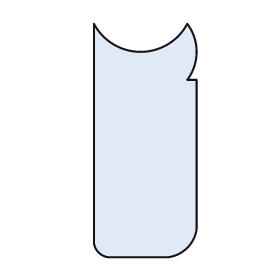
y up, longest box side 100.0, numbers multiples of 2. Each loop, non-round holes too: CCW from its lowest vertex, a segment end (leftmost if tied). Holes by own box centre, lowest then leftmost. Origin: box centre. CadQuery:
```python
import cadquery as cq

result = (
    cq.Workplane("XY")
    .moveTo(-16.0, -50.0)
    .lineTo(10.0, -50.0)
    .threePointArc((18.0, -46.0), (22.0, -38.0))
    .lineTo(22.0, 26.0)
    .lineTo(18.0, 26.0)
    .threePointArc((22.0, 38.0), (18.0, 50.0))
    .threePointArc((-2.0, 38.0), (-22.0, 50.0))
    .lineTo(-22.0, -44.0)
    .threePointArc((-20.0, -48.0), (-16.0, -50.0))
    .close()
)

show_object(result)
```